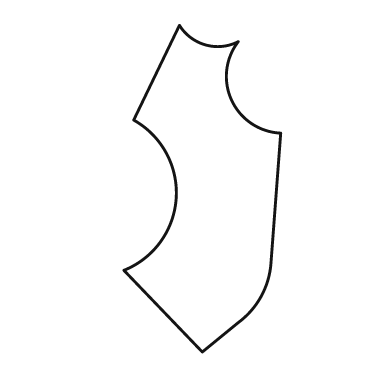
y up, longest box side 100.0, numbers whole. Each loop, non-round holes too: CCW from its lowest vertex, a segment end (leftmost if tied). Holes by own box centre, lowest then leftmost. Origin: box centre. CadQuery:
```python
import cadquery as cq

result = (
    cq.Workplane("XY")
    .moveTo(0.0, -50.0)
    .lineTo(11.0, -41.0)
    .threePointArc((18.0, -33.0), (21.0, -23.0))
    .lineTo(24.0, 17.0)
    .threePointArc((9.0, 27.0), (11.0, 45.0))
    .threePointArc((1.0, 44.0), (-7.0, 50.0))
    .lineTo(-21.0, 21.0)
    .threePointArc((-8.0, -3.0), (-24.0, -25.0))
    .close()
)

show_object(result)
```